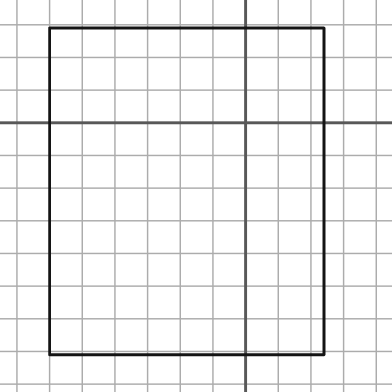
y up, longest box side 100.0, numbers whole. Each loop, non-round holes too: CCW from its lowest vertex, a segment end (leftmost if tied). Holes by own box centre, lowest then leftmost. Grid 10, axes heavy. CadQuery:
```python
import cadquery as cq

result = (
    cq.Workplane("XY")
    .moveTo(-60.0, -71.0)
    .lineTo(24.0, -71.0)
    .lineTo(24.0, 29.0)
    .lineTo(-60.0, 29.0)
    .close()
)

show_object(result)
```